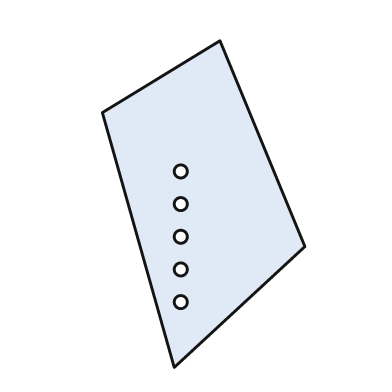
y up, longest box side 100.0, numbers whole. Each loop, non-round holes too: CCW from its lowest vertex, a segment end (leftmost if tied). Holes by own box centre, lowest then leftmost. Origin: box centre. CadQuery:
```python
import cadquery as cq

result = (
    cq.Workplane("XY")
    .moveTo(-9.0, -50.0)
    .lineTo(31.0, -13.0)
    .lineTo(5.0, 50.0)
    .lineTo(-31.0, 28.0)
    .close()
    .moveTo(-7.0, -30.0)
    .circle(2.0)
    .moveTo(-7.0, -20.0)
    .circle(2.0)
    .moveTo(-7.0, -10.0)
    .circle(2.0)
    .moveTo(-7.0, 0.0)
    .circle(2.0)
    .moveTo(-7.0, 10.0)
    .circle(2.0)
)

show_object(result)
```